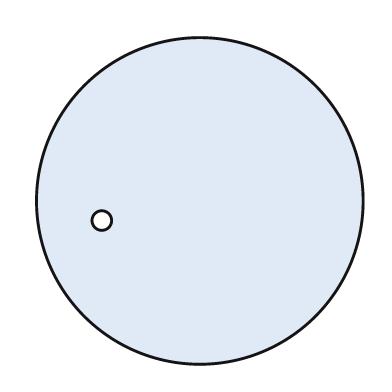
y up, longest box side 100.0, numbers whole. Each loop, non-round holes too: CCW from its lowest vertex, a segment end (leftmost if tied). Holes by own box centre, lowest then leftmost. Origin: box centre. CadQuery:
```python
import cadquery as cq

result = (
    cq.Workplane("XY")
    .moveTo(0.0, 0.0)
    .circle(50.0)
    .moveTo(-30.0, -6.0)
    .circle(3.0)
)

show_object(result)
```